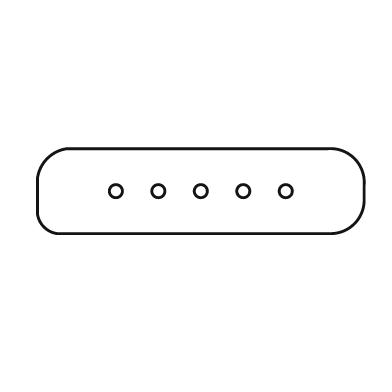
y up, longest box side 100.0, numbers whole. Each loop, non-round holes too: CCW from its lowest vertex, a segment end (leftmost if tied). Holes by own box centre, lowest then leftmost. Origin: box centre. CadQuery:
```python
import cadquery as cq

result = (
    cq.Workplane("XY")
    .moveTo(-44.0, -13.0)
    .lineTo(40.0, -13.0)
    .threePointArc((47.0, -10.0), (50.0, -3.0))
    .lineTo(50.0, 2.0)
    .threePointArc((47.0, 10.0), (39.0, 13.0))
    .lineTo(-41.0, 13.0)
    .threePointArc((-47.0, 10.0), (-50.0, 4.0))
    .lineTo(-50.0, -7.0)
    .threePointArc((-48.0, -11.0), (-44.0, -13.0))
    .close()
    .moveTo(-26.0, 0.0)
    .circle(2.0)
    .moveTo(-13.0, 0.0)
    .circle(2.0)
    .moveTo(0.0, 0.0)
    .circle(2.0)
    .moveTo(13.0, 0.0)
    .circle(2.0)
    .moveTo(26.0, 0.0)
    .circle(2.0)
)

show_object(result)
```